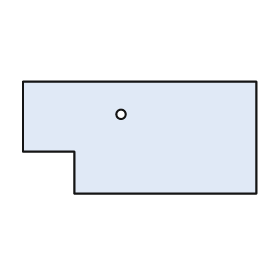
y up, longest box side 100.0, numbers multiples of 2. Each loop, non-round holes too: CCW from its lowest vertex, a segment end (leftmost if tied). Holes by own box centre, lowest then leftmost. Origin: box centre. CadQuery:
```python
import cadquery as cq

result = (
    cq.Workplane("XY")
    .moveTo(-28.0, -24.0)
    .lineTo(50.0, -24.0)
    .lineTo(50.0, 24.0)
    .lineTo(-50.0, 24.0)
    .lineTo(-50.0, -6.0)
    .lineTo(-28.0, -6.0)
    .close()
    .moveTo(-8.0, 10.0)
    .circle(2.0)
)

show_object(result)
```